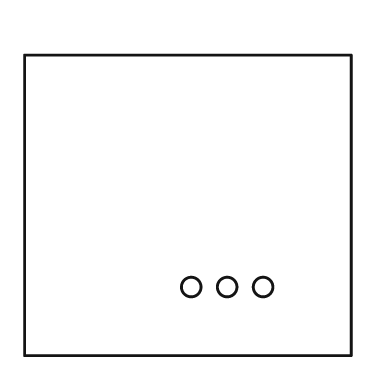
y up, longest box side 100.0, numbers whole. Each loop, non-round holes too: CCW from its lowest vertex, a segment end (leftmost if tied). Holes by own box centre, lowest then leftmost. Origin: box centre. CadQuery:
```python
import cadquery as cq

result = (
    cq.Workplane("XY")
    .moveTo(-50.0, -46.0)
    .lineTo(50.0, -46.0)
    .lineTo(50.0, 46.0)
    .lineTo(-50.0, 46.0)
    .close()
    .moveTo(1.0, -25.0)
    .circle(3.0)
    .moveTo(12.0, -25.0)
    .circle(3.0)
    .moveTo(23.0, -25.0)
    .circle(3.0)
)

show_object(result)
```